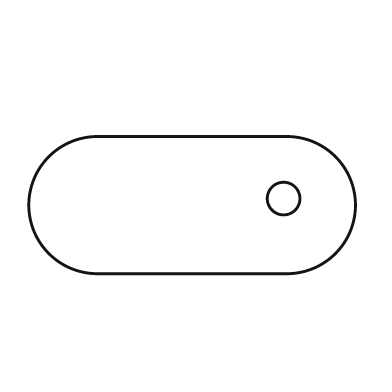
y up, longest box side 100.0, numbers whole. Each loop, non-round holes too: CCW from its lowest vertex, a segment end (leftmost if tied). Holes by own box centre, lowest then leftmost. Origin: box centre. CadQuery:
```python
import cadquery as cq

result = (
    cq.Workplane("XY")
    .moveTo(-29.0, -21.0)
    .lineTo(29.0, -21.0)
    .threePointArc((50.0, 0.0), (29.0, 21.0))
    .lineTo(-29.0, 21.0)
    .threePointArc((-50.0, 0.0), (-29.0, -21.0))
    .close()
    .moveTo(28.0, 2.0)
    .circle(5.0)
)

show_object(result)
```